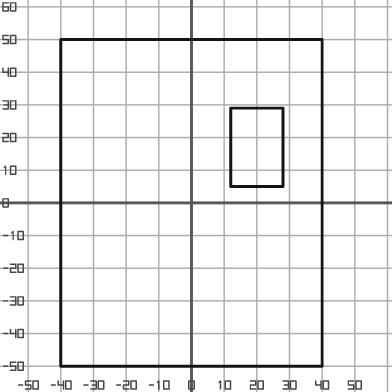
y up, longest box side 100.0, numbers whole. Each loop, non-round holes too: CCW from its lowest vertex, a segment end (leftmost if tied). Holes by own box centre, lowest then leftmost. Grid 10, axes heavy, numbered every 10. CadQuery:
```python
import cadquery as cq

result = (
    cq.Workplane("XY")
    .moveTo(-40.0, -50.0)
    .lineTo(40.0, -50.0)
    .lineTo(40.0, 50.0)
    .lineTo(-40.0, 50.0)
    .close()
    .moveTo(12.0, 5.0)
    .lineTo(28.0, 5.0)
    .lineTo(28.0, 29.0)
    .lineTo(12.0, 29.0)
    .close()
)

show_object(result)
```